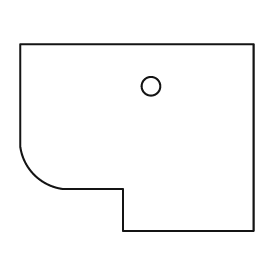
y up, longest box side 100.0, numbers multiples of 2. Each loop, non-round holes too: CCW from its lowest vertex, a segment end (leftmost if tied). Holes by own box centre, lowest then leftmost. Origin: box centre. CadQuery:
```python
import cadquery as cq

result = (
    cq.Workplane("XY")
    .moveTo(-6.0, -40.0)
    .lineTo(50.0, -40.0)
    .lineTo(50.0, 40.0)
    .lineTo(-50.0, 40.0)
    .lineTo(-50.0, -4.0)
    .threePointArc((-44.0, -16.0), (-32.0, -22.0))
    .lineTo(-6.0, -22.0)
    .close()
    .moveTo(6.0, 22.0)
    .circle(4.0)
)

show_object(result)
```